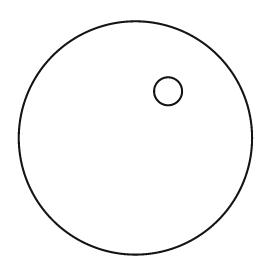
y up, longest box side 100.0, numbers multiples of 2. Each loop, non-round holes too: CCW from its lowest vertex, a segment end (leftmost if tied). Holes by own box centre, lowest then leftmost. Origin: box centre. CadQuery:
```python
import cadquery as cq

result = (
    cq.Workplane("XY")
    .moveTo(0.0, 0.0)
    .circle(50.0)
    .moveTo(14.0, 20.0)
    .circle(6.0)
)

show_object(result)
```